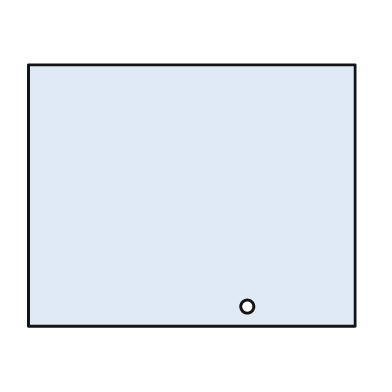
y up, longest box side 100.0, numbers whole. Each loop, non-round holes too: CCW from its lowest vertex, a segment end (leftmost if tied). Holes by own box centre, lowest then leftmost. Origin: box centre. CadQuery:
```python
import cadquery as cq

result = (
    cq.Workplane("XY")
    .moveTo(-50.0, -40.0)
    .lineTo(50.0, -40.0)
    .lineTo(50.0, 40.0)
    .lineTo(-50.0, 40.0)
    .close()
    .moveTo(17.0, -34.0)
    .circle(2.0)
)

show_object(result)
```